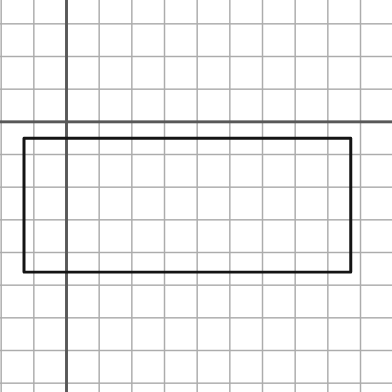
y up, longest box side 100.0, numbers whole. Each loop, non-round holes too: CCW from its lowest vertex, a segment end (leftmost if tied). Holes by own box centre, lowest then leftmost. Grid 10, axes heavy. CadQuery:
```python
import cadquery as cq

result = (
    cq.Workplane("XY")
    .moveTo(-13.0, -46.0)
    .lineTo(87.0, -46.0)
    .lineTo(87.0, -5.0)
    .lineTo(-13.0, -5.0)
    .close()
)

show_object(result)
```